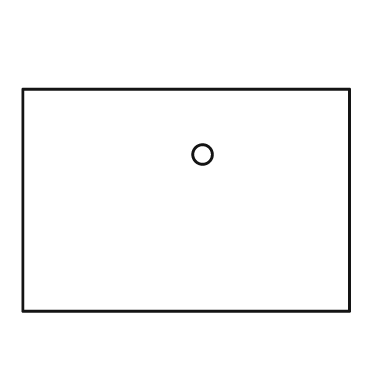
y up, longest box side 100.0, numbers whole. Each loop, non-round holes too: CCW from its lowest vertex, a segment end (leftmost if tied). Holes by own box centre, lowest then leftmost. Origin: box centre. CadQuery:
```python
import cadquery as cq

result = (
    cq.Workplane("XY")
    .moveTo(-50.0, -34.0)
    .lineTo(50.0, -34.0)
    .lineTo(50.0, 34.0)
    .lineTo(-50.0, 34.0)
    .close()
    .moveTo(5.0, 14.0)
    .circle(3.0)
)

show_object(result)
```